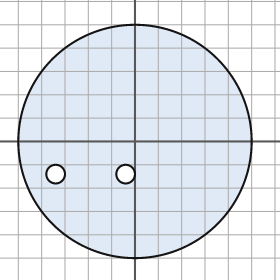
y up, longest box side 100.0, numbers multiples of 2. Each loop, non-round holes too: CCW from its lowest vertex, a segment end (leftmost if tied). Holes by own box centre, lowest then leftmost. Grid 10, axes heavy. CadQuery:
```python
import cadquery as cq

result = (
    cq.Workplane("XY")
    .moveTo(0.0, 0.0)
    .circle(50.0)
    .moveTo(-34.0, -14.0)
    .circle(4.0)
    .moveTo(-4.0, -14.0)
    .circle(4.0)
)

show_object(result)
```